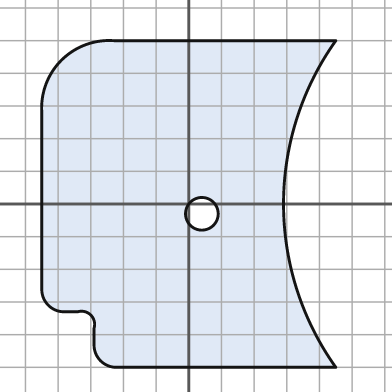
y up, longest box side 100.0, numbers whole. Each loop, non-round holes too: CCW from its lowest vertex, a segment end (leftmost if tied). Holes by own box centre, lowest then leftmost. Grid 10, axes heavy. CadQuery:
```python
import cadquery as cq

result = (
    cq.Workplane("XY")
    .moveTo(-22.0, -50.0)
    .lineTo(45.0, -50.0)
    .threePointArc((29.0, 0.0), (45.0, 50.0))
    .lineTo(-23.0, 50.0)
    .threePointArc((-39.0, 44.0), (-45.0, 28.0))
    .lineTo(-45.0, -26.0)
    .threePointArc((-43.0, -31.0), (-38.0, -33.0))
    .lineTo(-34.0, -33.0)
    .threePointArc((-30.0, -34.0), (-29.0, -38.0))
    .lineTo(-29.0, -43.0)
    .threePointArc((-27.0, -48.0), (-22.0, -50.0))
    .close()
    .moveTo(4.0, -3.0)
    .circle(5.0)
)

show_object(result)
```